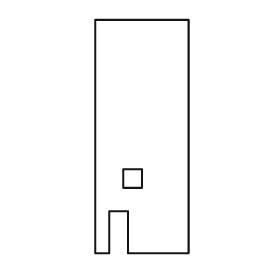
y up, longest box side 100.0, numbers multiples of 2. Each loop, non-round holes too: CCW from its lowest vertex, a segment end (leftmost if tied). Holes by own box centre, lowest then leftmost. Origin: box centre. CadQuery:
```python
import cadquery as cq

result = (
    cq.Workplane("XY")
    .moveTo(-20.0, -50.0)
    .lineTo(-14.0, -50.0)
    .lineTo(-14.0, -32.0)
    .lineTo(-6.0, -32.0)
    .lineTo(-6.0, -50.0)
    .lineTo(20.0, -50.0)
    .lineTo(20.0, 50.0)
    .lineTo(-20.0, 50.0)
    .close()
    .moveTo(-8.0, -22.0)
    .lineTo(0.0, -22.0)
    .lineTo(0.0, -14.0)
    .lineTo(-8.0, -14.0)
    .close()
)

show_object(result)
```